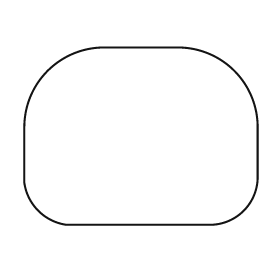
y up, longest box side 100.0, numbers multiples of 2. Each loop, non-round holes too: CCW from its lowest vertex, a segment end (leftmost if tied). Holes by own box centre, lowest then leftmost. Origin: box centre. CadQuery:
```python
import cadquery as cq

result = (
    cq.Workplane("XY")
    .moveTo(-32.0, -38.0)
    .lineTo(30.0, -38.0)
    .threePointArc((44.0, -32.0), (50.0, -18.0))
    .lineTo(50.0, 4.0)
    .threePointArc((40.0, 28.0), (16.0, 38.0))
    .lineTo(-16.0, 38.0)
    .threePointArc((-40.0, 28.0), (-50.0, 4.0))
    .lineTo(-50.0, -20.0)
    .threePointArc((-44.0, -32.0), (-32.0, -38.0))
    .close()
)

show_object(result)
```